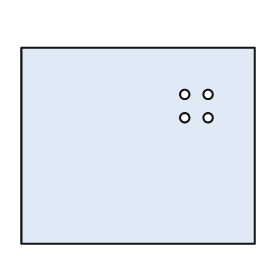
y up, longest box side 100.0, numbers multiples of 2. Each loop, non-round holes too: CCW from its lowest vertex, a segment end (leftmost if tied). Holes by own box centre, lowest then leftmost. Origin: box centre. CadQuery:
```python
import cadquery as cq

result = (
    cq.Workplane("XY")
    .moveTo(-50.0, -42.0)
    .lineTo(50.0, -42.0)
    .lineTo(50.0, 42.0)
    .lineTo(-50.0, 42.0)
    .close()
    .moveTo(20.0, 12.0)
    .circle(2.0)
    .moveTo(30.0, 12.0)
    .circle(2.0)
    .moveTo(20.0, 22.0)
    .circle(2.0)
    .moveTo(30.0, 22.0)
    .circle(2.0)
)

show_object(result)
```